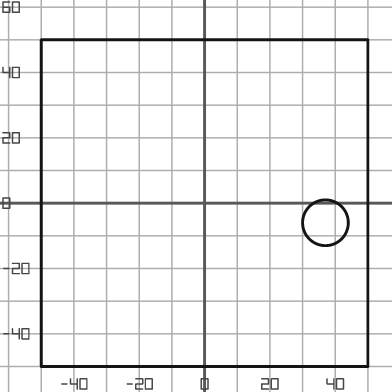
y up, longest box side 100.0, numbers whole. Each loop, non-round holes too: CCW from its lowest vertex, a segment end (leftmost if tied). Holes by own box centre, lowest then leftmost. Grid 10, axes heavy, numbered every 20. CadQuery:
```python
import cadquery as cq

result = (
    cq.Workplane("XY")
    .moveTo(-50.0, -50.0)
    .lineTo(50.0, -50.0)
    .lineTo(50.0, 50.0)
    .lineTo(-50.0, 50.0)
    .close()
    .moveTo(37.0, -6.0)
    .circle(7.0)
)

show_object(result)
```